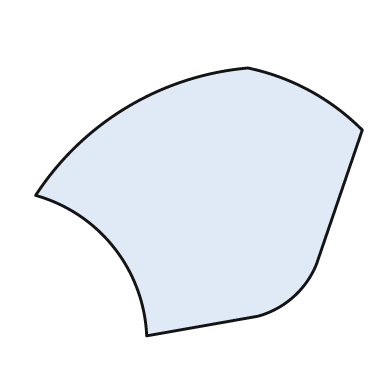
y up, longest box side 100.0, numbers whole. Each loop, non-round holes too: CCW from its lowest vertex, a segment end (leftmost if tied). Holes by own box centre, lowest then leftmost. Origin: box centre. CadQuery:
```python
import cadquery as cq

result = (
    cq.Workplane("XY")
    .moveTo(-16.0, -41.0)
    .lineTo(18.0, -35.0)
    .threePointArc((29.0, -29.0), (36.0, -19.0))
    .lineTo(50.0, 22.0)
    .threePointArc((34.0, 34.0), (15.0, 41.0))
    .threePointArc((-22.0, 29.0), (-50.0, 2.0))
    .threePointArc((-26.0, -14.0), (-16.0, -41.0))
    .close()
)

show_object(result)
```